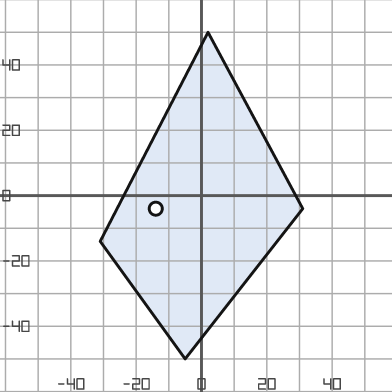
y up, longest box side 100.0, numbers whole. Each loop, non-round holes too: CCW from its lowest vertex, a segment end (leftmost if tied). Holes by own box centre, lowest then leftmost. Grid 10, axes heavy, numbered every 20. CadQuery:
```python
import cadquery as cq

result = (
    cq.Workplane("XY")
    .moveTo(-5.0, -50.0)
    .lineTo(31.0, -4.0)
    .lineTo(2.0, 50.0)
    .lineTo(-31.0, -14.0)
    .close()
    .moveTo(-14.0, -4.0)
    .circle(2.0)
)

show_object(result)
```